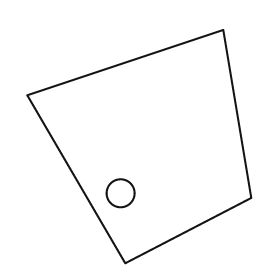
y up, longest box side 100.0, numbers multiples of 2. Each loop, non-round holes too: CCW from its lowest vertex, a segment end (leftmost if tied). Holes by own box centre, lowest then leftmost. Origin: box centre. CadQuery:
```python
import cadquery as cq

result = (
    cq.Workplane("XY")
    .moveTo(-6.0, -50.0)
    .lineTo(48.0, -22.0)
    .lineTo(36.0, 50.0)
    .lineTo(-48.0, 22.0)
    .close()
    .moveTo(-8.0, -20.0)
    .circle(6.0)
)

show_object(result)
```